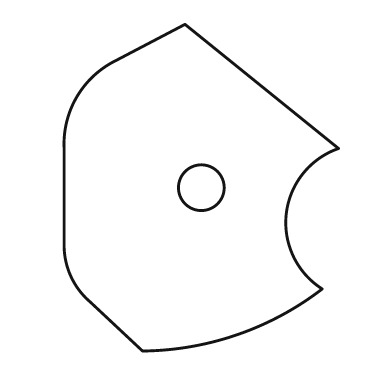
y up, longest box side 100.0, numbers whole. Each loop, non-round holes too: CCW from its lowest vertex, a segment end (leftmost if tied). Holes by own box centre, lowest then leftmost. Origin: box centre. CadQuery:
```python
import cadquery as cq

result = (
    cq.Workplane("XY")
    .moveTo(-18.0, -50.0)
    .threePointArc((11.0, -45.0), (37.0, -31.0))
    .threePointArc((26.0, -8.0), (42.0, 12.0))
    .lineTo(-5.0, 50.0)
    .lineTo(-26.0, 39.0)
    .threePointArc((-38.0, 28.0), (-42.0, 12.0))
    .lineTo(-42.0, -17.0)
    .threePointArc((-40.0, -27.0), (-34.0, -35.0))
    .close()
    .moveTo(0.0, 0.0)
    .circle(7.0)
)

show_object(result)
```